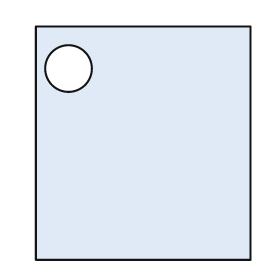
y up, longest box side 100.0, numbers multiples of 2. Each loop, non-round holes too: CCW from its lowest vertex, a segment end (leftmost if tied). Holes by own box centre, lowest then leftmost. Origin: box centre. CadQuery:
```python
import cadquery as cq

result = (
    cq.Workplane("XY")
    .moveTo(-46.0, -50.0)
    .lineTo(46.0, -50.0)
    .lineTo(46.0, 50.0)
    .lineTo(-46.0, 50.0)
    .close()
    .moveTo(-32.0, 32.0)
    .circle(10.0)
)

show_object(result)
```